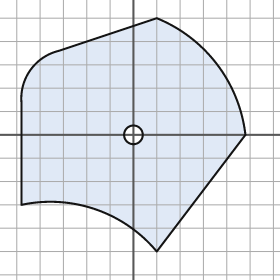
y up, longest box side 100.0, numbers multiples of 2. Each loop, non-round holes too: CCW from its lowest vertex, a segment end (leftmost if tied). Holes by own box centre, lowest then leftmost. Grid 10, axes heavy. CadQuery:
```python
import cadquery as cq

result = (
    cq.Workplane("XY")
    .moveTo(10.0, -50.0)
    .lineTo(48.0, 0.0)
    .threePointArc((36.0, 30.0), (10.0, 50.0))
    .lineTo(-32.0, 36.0)
    .threePointArc((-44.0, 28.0), (-48.0, 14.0))
    .lineTo(-48.0, -30.0)
    .threePointArc((-16.0, -32.0), (10.0, -50.0))
    .close()
    .moveTo(0.0, 0.0)
    .circle(4.0)
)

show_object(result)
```